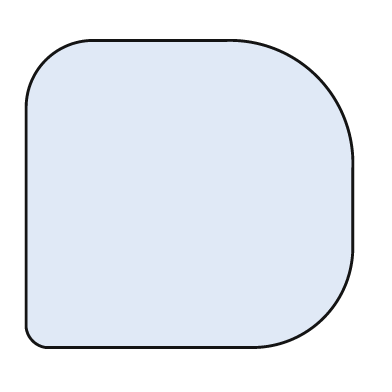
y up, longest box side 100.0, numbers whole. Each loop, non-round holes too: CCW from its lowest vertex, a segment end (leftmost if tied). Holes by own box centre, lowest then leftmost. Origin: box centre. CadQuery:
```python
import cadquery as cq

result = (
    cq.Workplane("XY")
    .moveTo(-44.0, -47.0)
    .lineTo(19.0, -47.0)
    .threePointArc((41.0, -38.0), (50.0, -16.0))
    .lineTo(50.0, 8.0)
    .threePointArc((39.0, 36.0), (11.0, 47.0))
    .lineTo(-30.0, 47.0)
    .threePointArc((-44.0, 41.0), (-50.0, 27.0))
    .lineTo(-50.0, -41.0)
    .threePointArc((-48.0, -45.0), (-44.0, -47.0))
    .close()
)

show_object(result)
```